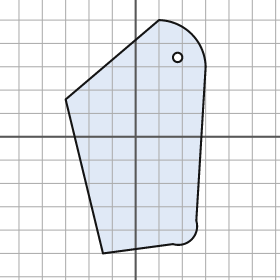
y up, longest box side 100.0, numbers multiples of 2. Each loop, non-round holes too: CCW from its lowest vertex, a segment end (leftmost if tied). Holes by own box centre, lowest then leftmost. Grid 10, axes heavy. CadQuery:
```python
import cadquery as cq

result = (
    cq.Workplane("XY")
    .moveTo(-14.0, -50.0)
    .lineTo(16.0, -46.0)
    .threePointArc((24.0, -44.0), (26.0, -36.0))
    .lineTo(30.0, 30.0)
    .threePointArc((24.0, 44.0), (10.0, 50.0))
    .lineTo(-30.0, 16.0)
    .close()
    .moveTo(18.0, 34.0)
    .circle(2.0)
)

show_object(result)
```